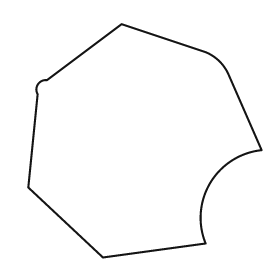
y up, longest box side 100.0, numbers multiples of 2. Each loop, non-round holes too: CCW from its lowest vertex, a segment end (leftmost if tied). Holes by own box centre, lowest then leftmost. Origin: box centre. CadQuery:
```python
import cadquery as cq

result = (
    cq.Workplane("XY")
    .moveTo(-18.0, -50.0)
    .lineTo(26.0, -44.0)
    .threePointArc((28.0, -18.0), (50.0, -4.0))
    .lineTo(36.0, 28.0)
    .threePointArc((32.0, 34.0), (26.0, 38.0))
    .lineTo(-10.0, 50.0)
    .lineTo(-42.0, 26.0)
    .threePointArc((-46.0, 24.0), (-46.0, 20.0))
    .lineTo(-50.0, -20.0)
    .close()
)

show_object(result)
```